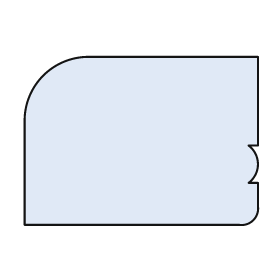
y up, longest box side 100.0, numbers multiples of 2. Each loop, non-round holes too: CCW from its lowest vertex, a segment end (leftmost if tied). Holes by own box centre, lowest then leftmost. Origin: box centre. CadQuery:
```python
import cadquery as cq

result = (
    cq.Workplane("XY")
    .moveTo(-50.0, -36.0)
    .lineTo(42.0, -36.0)
    .threePointArc((48.0, -34.0), (50.0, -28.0))
    .lineTo(50.0, -18.0)
    .lineTo(46.0, -18.0)
    .threePointArc((50.0, -10.0), (46.0, -2.0))
    .lineTo(50.0, -2.0)
    .lineTo(50.0, 36.0)
    .lineTo(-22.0, 36.0)
    .threePointArc((-42.0, 28.0), (-50.0, 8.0))
    .close()
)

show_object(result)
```